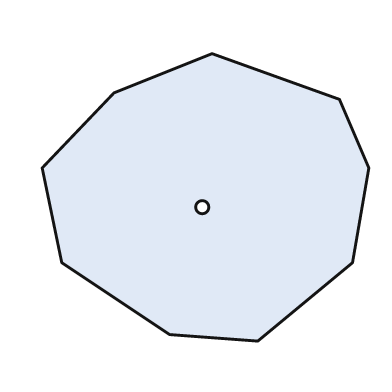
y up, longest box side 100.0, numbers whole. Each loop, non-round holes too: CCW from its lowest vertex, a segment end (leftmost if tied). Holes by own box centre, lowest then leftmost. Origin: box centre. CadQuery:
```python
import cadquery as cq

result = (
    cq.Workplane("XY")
    .moveTo(16.0, -44.0)
    .lineTo(45.0, -20.0)
    .lineTo(50.0, 9.0)
    .lineTo(41.0, 30.0)
    .lineTo(2.0, 44.0)
    .lineTo(-28.0, 32.0)
    .lineTo(-50.0, 9.0)
    .lineTo(-44.0, -20.0)
    .lineTo(-11.0, -42.0)
    .close()
    .moveTo(-1.0, -3.0)
    .circle(2.0)
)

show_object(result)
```